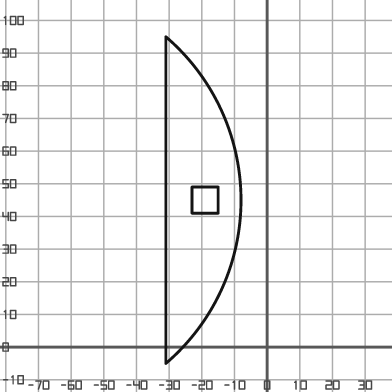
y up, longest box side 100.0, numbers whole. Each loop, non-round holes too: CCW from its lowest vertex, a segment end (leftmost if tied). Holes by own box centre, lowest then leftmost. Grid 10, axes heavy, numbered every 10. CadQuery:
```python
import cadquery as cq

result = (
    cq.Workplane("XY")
    .moveTo(-31.0, -5.0)
    .threePointArc((-8.0, 45.0), (-31.0, 95.0))
    .close()
    .moveTo(-23.0, 41.0)
    .lineTo(-15.0, 41.0)
    .lineTo(-15.0, 49.0)
    .lineTo(-23.0, 49.0)
    .close()
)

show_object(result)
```